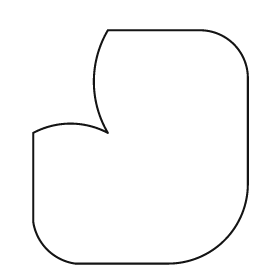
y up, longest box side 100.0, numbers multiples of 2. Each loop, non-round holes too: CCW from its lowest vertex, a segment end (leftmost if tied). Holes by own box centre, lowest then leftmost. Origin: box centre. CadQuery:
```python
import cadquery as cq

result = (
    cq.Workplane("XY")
    .moveTo(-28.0, -50.0)
    .lineTo(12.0, -50.0)
    .threePointArc((36.0, -40.0), (46.0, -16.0))
    .lineTo(46.0, 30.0)
    .threePointArc((40.0, 44.0), (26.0, 50.0))
    .lineTo(-14.0, 50.0)
    .threePointArc((-20.0, 28.0), (-14.0, 6.0))
    .threePointArc((-30.0, 10.0), (-46.0, 6.0))
    .lineTo(-46.0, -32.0)
    .threePointArc((-40.0, -44.0), (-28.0, -50.0))
    .close()
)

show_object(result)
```